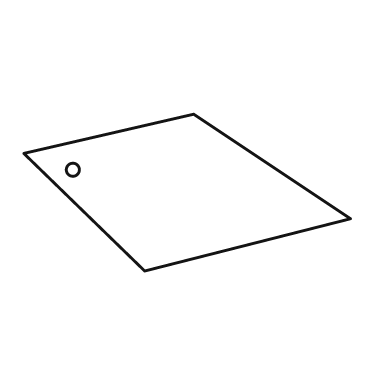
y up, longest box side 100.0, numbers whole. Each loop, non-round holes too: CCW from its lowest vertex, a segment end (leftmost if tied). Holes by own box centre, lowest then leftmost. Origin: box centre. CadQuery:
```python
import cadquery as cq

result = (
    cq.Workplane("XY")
    .moveTo(-13.0, -24.0)
    .lineTo(50.0, -8.0)
    .lineTo(2.0, 24.0)
    .lineTo(-50.0, 12.0)
    .close()
    .moveTo(-35.0, 7.0)
    .circle(2.0)
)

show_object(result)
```